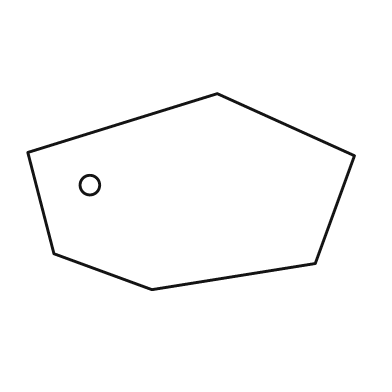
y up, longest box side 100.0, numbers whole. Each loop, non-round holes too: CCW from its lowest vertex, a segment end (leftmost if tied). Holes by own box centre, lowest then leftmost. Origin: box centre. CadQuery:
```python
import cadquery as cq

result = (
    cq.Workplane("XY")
    .moveTo(-12.0, -30.0)
    .lineTo(38.0, -22.0)
    .lineTo(50.0, 11.0)
    .lineTo(8.0, 30.0)
    .lineTo(-50.0, 12.0)
    .lineTo(-42.0, -19.0)
    .close()
    .moveTo(-31.0, 2.0)
    .circle(3.0)
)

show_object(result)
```